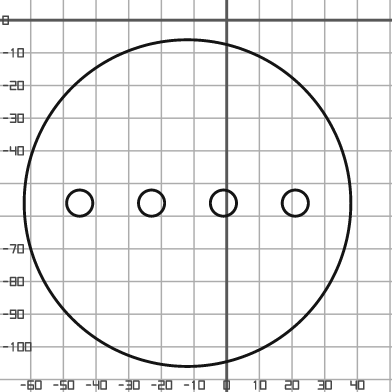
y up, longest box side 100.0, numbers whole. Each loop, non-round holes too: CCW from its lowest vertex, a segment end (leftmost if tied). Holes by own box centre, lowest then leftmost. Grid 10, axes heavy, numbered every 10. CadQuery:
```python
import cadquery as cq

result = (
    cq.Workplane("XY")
    .moveTo(-12.0, -56.0)
    .circle(50.0)
    .moveTo(-45.0, -56.0)
    .circle(4.0)
    .moveTo(-23.0, -56.0)
    .circle(4.0)
    .moveTo(-1.0, -56.0)
    .circle(4.0)
    .moveTo(21.0, -56.0)
    .circle(4.0)
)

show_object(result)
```